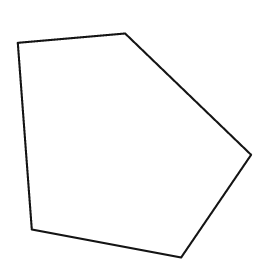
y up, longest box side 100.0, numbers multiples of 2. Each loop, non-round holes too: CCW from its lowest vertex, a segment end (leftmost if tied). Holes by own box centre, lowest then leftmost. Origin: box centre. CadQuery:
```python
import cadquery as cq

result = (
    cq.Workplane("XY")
    .moveTo(20.0, -48.0)
    .lineTo(50.0, -4.0)
    .lineTo(-4.0, 48.0)
    .lineTo(-50.0, 44.0)
    .lineTo(-44.0, -36.0)
    .close()
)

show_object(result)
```